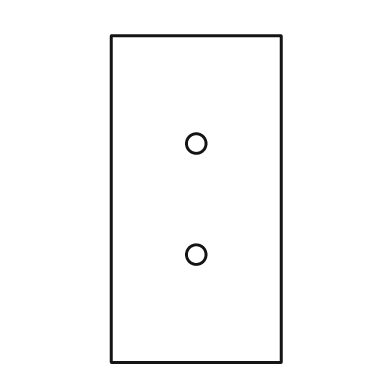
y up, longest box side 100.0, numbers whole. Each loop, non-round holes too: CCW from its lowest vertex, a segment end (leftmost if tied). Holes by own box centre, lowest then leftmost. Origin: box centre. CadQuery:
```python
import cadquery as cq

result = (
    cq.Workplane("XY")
    .moveTo(-26.0, -50.0)
    .lineTo(26.0, -50.0)
    .lineTo(26.0, 50.0)
    .lineTo(-26.0, 50.0)
    .close()
    .moveTo(0.0, -17.0)
    .circle(3.0)
    .moveTo(0.0, 17.0)
    .circle(3.0)
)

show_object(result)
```